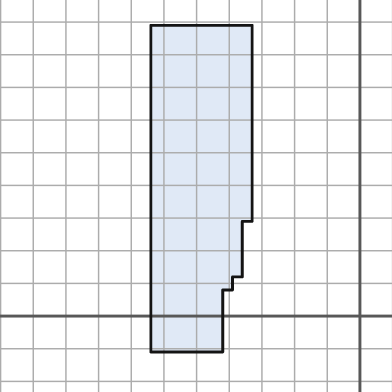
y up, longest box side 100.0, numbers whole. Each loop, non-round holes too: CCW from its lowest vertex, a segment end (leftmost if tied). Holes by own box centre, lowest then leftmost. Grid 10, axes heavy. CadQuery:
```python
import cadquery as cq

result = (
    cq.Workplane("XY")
    .moveTo(-64.0, -11.0)
    .lineTo(-42.0, -11.0)
    .lineTo(-42.0, 8.0)
    .lineTo(-39.0, 8.0)
    .lineTo(-39.0, 12.0)
    .lineTo(-36.0, 12.0)
    .lineTo(-36.0, 29.0)
    .lineTo(-33.0, 29.0)
    .lineTo(-33.0, 89.0)
    .lineTo(-64.0, 89.0)
    .close()
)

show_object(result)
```